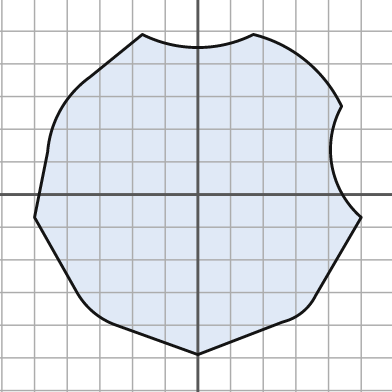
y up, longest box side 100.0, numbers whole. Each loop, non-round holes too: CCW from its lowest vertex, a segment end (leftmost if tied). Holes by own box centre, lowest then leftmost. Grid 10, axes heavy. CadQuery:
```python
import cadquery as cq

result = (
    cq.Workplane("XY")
    .moveTo(0.0, -49.0)
    .lineTo(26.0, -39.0)
    .threePointArc((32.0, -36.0), (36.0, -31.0))
    .lineTo(50.0, -7.0)
    .threePointArc((41.0, 9.0), (44.0, 27.0))
    .threePointArc((33.0, 41.0), (17.0, 49.0))
    .threePointArc((0.0, 45.0), (-17.0, 49.0))
    .lineTo(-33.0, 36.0)
    .threePointArc((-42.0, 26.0), (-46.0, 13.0))
    .lineTo(-50.0, -7.0)
    .lineTo(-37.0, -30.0)
    .threePointArc((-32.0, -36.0), (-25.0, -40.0))
    .close()
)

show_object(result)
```